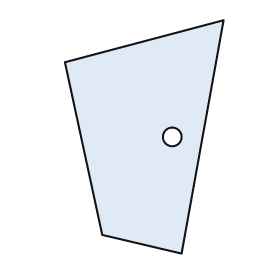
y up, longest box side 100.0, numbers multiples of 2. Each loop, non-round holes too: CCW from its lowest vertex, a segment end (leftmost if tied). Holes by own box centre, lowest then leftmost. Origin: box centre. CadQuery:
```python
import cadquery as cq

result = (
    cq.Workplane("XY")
    .moveTo(16.0, -50.0)
    .lineTo(34.0, 50.0)
    .lineTo(-34.0, 32.0)
    .lineTo(-18.0, -42.0)
    .close()
    .moveTo(12.0, 0.0)
    .circle(4.0)
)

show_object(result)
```